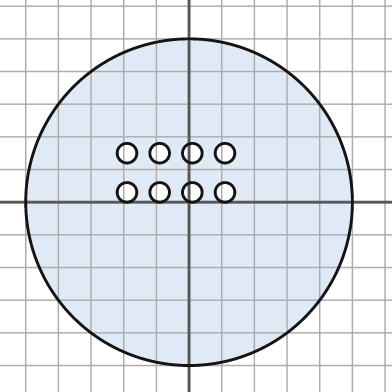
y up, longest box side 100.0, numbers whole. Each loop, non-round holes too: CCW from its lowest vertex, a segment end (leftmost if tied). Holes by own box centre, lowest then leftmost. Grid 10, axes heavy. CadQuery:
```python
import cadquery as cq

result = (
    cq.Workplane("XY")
    .moveTo(0.0, 0.0)
    .circle(50.0)
    .moveTo(-19.0, 3.0)
    .circle(3.0)
    .moveTo(-9.0, 3.0)
    .circle(3.0)
    .moveTo(1.0, 3.0)
    .circle(3.0)
    .moveTo(11.0, 3.0)
    .circle(3.0)
    .moveTo(-19.0, 15.0)
    .circle(3.0)
    .moveTo(-9.0, 15.0)
    .circle(3.0)
    .moveTo(1.0, 15.0)
    .circle(3.0)
    .moveTo(11.0, 15.0)
    .circle(3.0)
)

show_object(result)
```